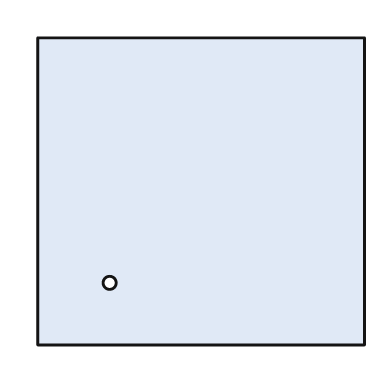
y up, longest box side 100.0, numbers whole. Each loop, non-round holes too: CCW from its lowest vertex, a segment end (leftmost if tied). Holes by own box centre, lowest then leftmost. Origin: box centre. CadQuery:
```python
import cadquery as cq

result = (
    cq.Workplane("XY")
    .moveTo(-50.0, -47.0)
    .lineTo(50.0, -47.0)
    .lineTo(50.0, 47.0)
    .lineTo(-50.0, 47.0)
    .close()
    .moveTo(-28.0, -28.0)
    .circle(2.0)
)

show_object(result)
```